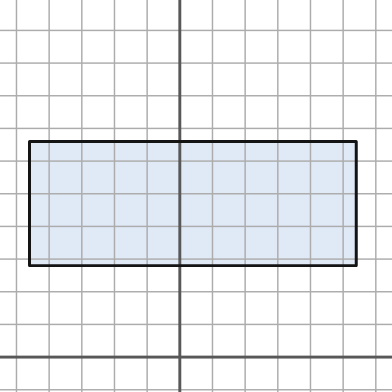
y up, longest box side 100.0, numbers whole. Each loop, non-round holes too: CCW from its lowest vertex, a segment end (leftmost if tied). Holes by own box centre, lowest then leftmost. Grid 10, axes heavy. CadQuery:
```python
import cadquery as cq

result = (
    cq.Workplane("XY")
    .moveTo(-46.0, 28.0)
    .lineTo(54.0, 28.0)
    .lineTo(54.0, 66.0)
    .lineTo(-46.0, 66.0)
    .close()
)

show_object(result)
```